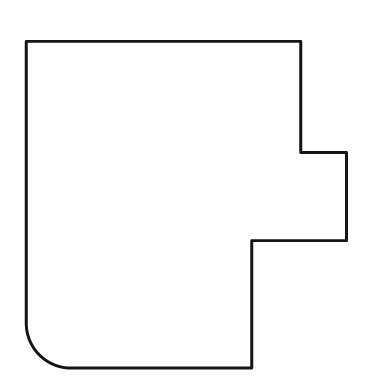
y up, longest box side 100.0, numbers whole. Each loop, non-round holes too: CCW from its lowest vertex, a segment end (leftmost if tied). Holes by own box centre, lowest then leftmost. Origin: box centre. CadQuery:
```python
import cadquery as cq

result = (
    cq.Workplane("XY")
    .moveTo(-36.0, -50.0)
    .lineTo(20.0, -50.0)
    .lineTo(20.0, -11.0)
    .lineTo(49.0, -11.0)
    .lineTo(49.0, 16.0)
    .lineTo(35.0, 16.0)
    .lineTo(35.0, 50.0)
    .lineTo(-49.0, 50.0)
    .lineTo(-49.0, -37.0)
    .threePointArc((-45.0, -46.0), (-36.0, -50.0))
    .close()
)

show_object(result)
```